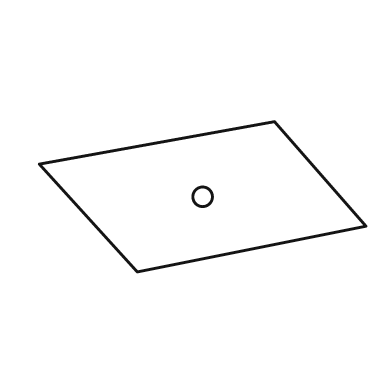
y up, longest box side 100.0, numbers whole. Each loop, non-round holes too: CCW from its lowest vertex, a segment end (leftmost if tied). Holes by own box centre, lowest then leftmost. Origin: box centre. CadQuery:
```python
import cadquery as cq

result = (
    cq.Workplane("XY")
    .moveTo(-20.0, -23.0)
    .lineTo(50.0, -9.0)
    .lineTo(22.0, 23.0)
    .lineTo(-50.0, 10.0)
    .close()
    .moveTo(0.0, 0.0)
    .circle(3.0)
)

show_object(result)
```